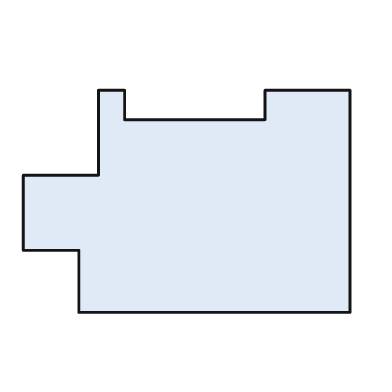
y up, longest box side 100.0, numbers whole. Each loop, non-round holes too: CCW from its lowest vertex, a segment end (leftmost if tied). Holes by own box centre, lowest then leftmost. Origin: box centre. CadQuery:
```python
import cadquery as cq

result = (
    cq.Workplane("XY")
    .moveTo(-33.0, -34.0)
    .lineTo(50.0, -34.0)
    .lineTo(50.0, 34.0)
    .lineTo(24.0, 34.0)
    .lineTo(24.0, 25.0)
    .lineTo(-19.0, 25.0)
    .lineTo(-19.0, 34.0)
    .lineTo(-27.0, 34.0)
    .lineTo(-27.0, 8.0)
    .lineTo(-50.0, 8.0)
    .lineTo(-50.0, -15.0)
    .lineTo(-33.0, -15.0)
    .close()
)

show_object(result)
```